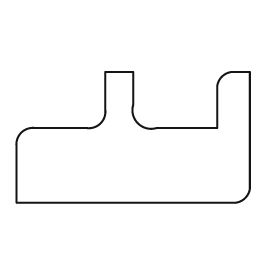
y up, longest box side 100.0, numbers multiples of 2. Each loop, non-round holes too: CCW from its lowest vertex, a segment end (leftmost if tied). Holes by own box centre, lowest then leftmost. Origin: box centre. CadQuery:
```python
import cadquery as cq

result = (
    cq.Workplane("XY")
    .moveTo(-50.0, -28.0)
    .lineTo(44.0, -28.0)
    .threePointArc((48.0, -26.0), (50.0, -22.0))
    .lineTo(50.0, 28.0)
    .lineTo(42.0, 28.0)
    .threePointArc((38.0, 26.0), (36.0, 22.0))
    .lineTo(36.0, 4.0)
    .lineTo(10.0, 4.0)
    .threePointArc((2.0, 6.0), (0.0, 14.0))
    .lineTo(0.0, 28.0)
    .lineTo(-12.0, 28.0)
    .lineTo(-12.0, 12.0)
    .threePointArc((-14.0, 6.0), (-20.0, 4.0))
    .lineTo(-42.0, 4.0)
    .threePointArc((-48.0, 2.0), (-50.0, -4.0))
    .close()
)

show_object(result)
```